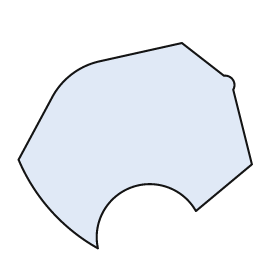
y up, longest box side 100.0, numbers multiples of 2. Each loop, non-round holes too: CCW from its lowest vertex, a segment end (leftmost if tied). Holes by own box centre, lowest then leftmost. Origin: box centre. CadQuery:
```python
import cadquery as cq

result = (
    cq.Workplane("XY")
    .moveTo(-16.0, -44.0)
    .threePointArc((-2.0, -18.0), (26.0, -28.0))
    .lineTo(50.0, -8.0)
    .lineTo(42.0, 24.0)
    .threePointArc((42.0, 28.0), (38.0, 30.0))
    .lineTo(20.0, 44.0)
    .lineTo(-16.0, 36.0)
    .threePointArc((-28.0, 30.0), (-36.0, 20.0))
    .lineTo(-50.0, -6.0)
    .threePointArc((-36.0, -28.0), (-16.0, -44.0))
    .close()
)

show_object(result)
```